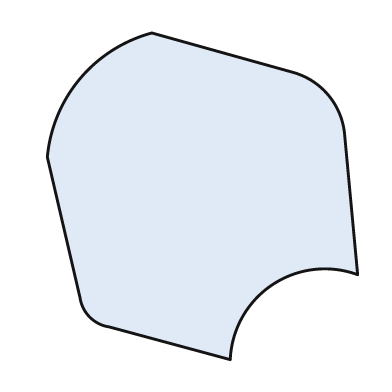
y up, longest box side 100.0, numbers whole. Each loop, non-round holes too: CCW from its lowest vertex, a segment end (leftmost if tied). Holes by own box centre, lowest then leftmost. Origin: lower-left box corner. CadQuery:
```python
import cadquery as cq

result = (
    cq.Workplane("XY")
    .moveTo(56.0, 0.0)
    .threePointArc((69.0, 23.0), (95.0, 26.0))
    .lineTo(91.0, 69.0)
    .threePointArc((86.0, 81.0), (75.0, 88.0))
    .lineTo(32.0, 100.0)
    .threePointArc((10.0, 86.0), (0.0, 62.0))
    .lineTo(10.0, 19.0)
    .threePointArc((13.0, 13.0), (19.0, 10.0))
    .close()
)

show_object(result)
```